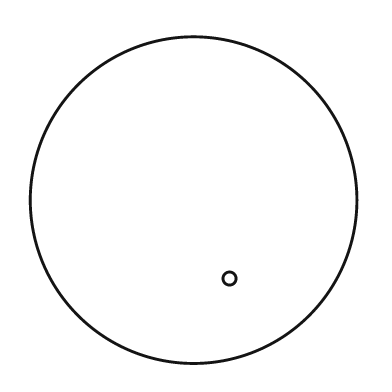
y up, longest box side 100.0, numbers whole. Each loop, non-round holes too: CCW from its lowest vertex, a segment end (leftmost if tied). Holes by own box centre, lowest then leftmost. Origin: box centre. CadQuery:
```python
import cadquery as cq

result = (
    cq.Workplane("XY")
    .moveTo(0.0, 0.0)
    .circle(50.0)
    .moveTo(11.0, -24.0)
    .circle(2.0)
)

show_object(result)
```